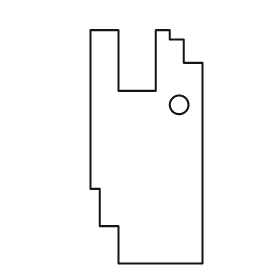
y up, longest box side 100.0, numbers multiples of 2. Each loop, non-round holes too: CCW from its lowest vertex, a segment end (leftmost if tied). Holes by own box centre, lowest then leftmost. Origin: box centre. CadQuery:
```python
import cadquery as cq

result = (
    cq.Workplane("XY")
    .moveTo(-12.0, -50.0)
    .lineTo(24.0, -50.0)
    .lineTo(24.0, 36.0)
    .lineTo(16.0, 36.0)
    .lineTo(16.0, 46.0)
    .lineTo(10.0, 46.0)
    .lineTo(10.0, 50.0)
    .lineTo(4.0, 50.0)
    .lineTo(4.0, 24.0)
    .lineTo(-12.0, 24.0)
    .lineTo(-12.0, 50.0)
    .lineTo(-24.0, 50.0)
    .lineTo(-24.0, -18.0)
    .lineTo(-20.0, -18.0)
    .lineTo(-20.0, -34.0)
    .lineTo(-12.0, -34.0)
    .close()
    .moveTo(14.0, 18.0)
    .circle(4.0)
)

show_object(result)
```